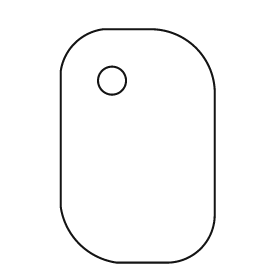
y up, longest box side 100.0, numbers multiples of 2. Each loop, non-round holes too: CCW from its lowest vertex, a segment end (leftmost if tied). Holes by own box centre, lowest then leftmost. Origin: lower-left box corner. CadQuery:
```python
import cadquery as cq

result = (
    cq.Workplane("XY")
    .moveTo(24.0, 0.0)
    .lineTo(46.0, 0.0)
    .threePointArc((60.0, 6.0), (66.0, 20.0))
    .lineTo(66.0, 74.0)
    .threePointArc((58.0, 92.0), (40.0, 100.0))
    .lineTo(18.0, 100.0)
    .threePointArc((6.0, 94.0), (0.0, 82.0))
    .lineTo(0.0, 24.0)
    .threePointArc((8.0, 8.0), (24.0, 0.0))
    .close()
    .moveTo(22.0, 78.0)
    .circle(6.0)
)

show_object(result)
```